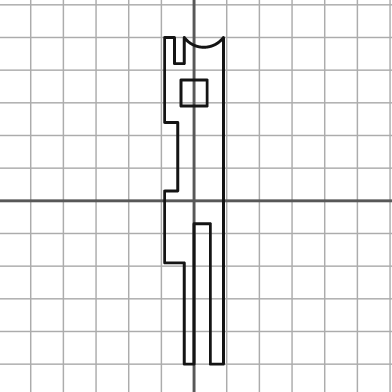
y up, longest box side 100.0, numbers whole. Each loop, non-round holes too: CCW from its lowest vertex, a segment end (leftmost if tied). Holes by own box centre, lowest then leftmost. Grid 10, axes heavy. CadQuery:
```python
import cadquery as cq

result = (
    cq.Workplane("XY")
    .moveTo(-3.0, -50.0)
    .lineTo(0.0, -50.0)
    .lineTo(0.0, -7.0)
    .lineTo(5.0, -7.0)
    .lineTo(5.0, -50.0)
    .lineTo(9.0, -50.0)
    .lineTo(9.0, 50.0)
    .threePointArc((3.0, 47.0), (-3.0, 50.0))
    .lineTo(-3.0, 42.0)
    .lineTo(-6.0, 42.0)
    .lineTo(-6.0, 50.0)
    .lineTo(-9.0, 50.0)
    .lineTo(-9.0, 24.0)
    .lineTo(-5.0, 24.0)
    .lineTo(-5.0, 3.0)
    .lineTo(-9.0, 3.0)
    .lineTo(-9.0, -19.0)
    .lineTo(-3.0, -19.0)
    .close()
    .moveTo(-4.0, 29.0)
    .lineTo(4.0, 29.0)
    .lineTo(4.0, 37.0)
    .lineTo(-4.0, 37.0)
    .close()
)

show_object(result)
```